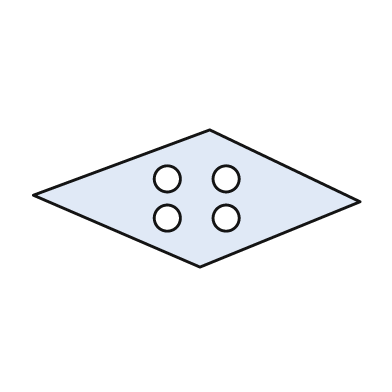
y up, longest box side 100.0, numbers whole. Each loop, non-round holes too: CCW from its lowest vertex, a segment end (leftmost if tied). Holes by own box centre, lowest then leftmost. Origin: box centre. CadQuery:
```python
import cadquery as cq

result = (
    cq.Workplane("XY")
    .moveTo(1.0, -21.0)
    .lineTo(50.0, -1.0)
    .lineTo(4.0, 21.0)
    .lineTo(-50.0, 1.0)
    .close()
    .moveTo(-9.0, -6.0)
    .circle(4.0)
    .moveTo(9.0, -6.0)
    .circle(4.0)
    .moveTo(-9.0, 6.0)
    .circle(4.0)
    .moveTo(9.0, 6.0)
    .circle(4.0)
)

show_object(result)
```